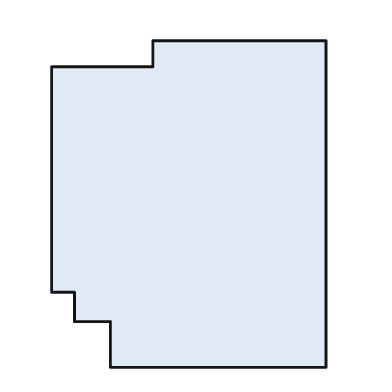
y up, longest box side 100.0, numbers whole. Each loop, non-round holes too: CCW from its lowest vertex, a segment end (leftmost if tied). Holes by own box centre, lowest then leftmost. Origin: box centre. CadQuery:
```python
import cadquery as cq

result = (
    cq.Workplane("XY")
    .moveTo(-24.0, -50.0)
    .lineTo(42.0, -50.0)
    .lineTo(42.0, 50.0)
    .lineTo(-11.0, 50.0)
    .lineTo(-11.0, 42.0)
    .lineTo(-42.0, 42.0)
    .lineTo(-42.0, -27.0)
    .lineTo(-35.0, -27.0)
    .lineTo(-35.0, -36.0)
    .lineTo(-24.0, -36.0)
    .close()
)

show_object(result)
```